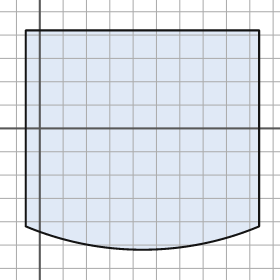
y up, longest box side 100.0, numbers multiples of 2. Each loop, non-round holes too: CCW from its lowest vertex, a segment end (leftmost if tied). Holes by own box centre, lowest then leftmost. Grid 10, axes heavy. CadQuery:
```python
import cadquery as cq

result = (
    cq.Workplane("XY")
    .moveTo(-6.0, -42.0)
    .threePointArc((44.0, -52.0), (94.0, -42.0))
    .lineTo(94.0, 42.0)
    .lineTo(-6.0, 42.0)
    .close()
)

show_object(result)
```